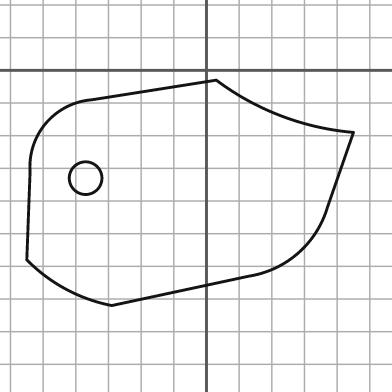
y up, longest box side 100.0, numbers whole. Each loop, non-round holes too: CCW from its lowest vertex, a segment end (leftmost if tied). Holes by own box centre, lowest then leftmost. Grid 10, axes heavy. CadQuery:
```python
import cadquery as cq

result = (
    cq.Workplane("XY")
    .moveTo(-29.0, -72.0)
    .lineTo(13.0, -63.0)
    .threePointArc((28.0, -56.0), (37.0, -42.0))
    .lineTo(45.0, -19.0)
    .threePointArc((23.0, -14.0), (3.0, -3.0))
    .lineTo(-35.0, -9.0)
    .threePointArc((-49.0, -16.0), (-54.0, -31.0))
    .lineTo(-55.0, -58.0)
    .threePointArc((-43.0, -67.0), (-29.0, -72.0))
    .close()
    .moveTo(-37.0, -33.0)
    .circle(5.0)
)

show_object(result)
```